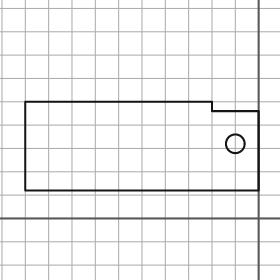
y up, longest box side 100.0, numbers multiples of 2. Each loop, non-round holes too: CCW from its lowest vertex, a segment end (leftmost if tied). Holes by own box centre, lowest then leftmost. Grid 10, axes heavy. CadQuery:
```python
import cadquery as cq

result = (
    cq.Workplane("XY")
    .moveTo(-100.0, 12.0)
    .lineTo(0.0, 12.0)
    .lineTo(0.0, 46.0)
    .lineTo(-20.0, 46.0)
    .lineTo(-20.0, 50.0)
    .lineTo(-100.0, 50.0)
    .close()
    .moveTo(-10.0, 32.0)
    .circle(4.0)
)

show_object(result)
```